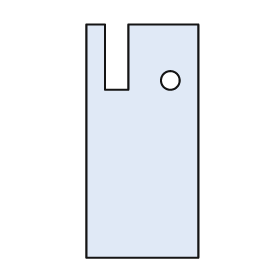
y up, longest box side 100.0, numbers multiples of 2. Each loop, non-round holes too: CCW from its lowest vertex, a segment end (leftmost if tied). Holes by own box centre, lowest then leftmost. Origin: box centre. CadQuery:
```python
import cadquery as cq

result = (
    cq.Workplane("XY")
    .moveTo(-24.0, -50.0)
    .lineTo(24.0, -50.0)
    .lineTo(24.0, 50.0)
    .lineTo(-6.0, 50.0)
    .lineTo(-6.0, 22.0)
    .lineTo(-16.0, 22.0)
    .lineTo(-16.0, 50.0)
    .lineTo(-24.0, 50.0)
    .close()
    .moveTo(12.0, 26.0)
    .circle(4.0)
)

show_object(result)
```